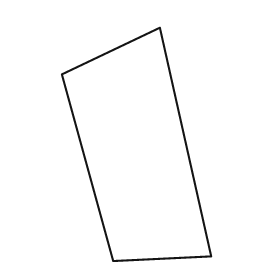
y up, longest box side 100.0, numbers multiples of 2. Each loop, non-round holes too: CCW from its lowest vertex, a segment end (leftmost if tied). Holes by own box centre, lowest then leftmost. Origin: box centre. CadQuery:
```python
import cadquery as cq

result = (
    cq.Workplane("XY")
    .moveTo(-10.0, -50.0)
    .lineTo(32.0, -48.0)
    .lineTo(10.0, 50.0)
    .lineTo(-32.0, 30.0)
    .close()
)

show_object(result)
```